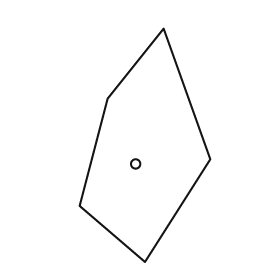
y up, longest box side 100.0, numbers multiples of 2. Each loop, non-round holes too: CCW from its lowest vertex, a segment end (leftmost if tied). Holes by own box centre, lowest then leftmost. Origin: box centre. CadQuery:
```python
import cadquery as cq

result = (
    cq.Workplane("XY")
    .moveTo(0.0, -50.0)
    .lineTo(28.0, -6.0)
    .lineTo(8.0, 50.0)
    .lineTo(-16.0, 20.0)
    .lineTo(-28.0, -26.0)
    .close()
    .moveTo(-4.0, -8.0)
    .circle(2.0)
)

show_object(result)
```